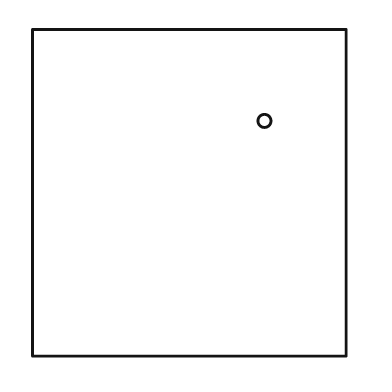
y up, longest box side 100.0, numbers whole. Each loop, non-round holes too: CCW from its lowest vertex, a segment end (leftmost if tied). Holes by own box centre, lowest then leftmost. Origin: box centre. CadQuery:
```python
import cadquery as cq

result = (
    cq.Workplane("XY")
    .moveTo(-48.0, -50.0)
    .lineTo(48.0, -50.0)
    .lineTo(48.0, 50.0)
    .lineTo(-48.0, 50.0)
    .close()
    .moveTo(23.0, 22.0)
    .circle(2.0)
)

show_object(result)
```